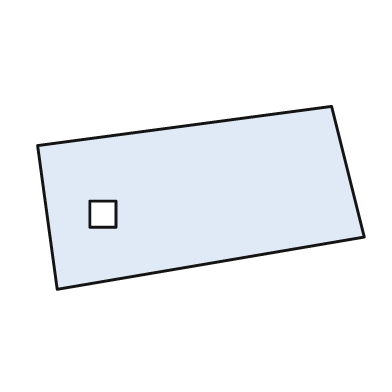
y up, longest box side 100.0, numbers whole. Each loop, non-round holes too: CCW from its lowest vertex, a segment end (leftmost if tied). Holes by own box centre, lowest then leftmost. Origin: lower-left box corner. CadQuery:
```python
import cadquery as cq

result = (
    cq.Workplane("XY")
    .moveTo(6.0, 0.0)
    .lineTo(100.0, 16.0)
    .lineTo(90.0, 56.0)
    .lineTo(0.0, 44.0)
    .close()
    .moveTo(16.0, 19.0)
    .lineTo(24.0, 19.0)
    .lineTo(24.0, 27.0)
    .lineTo(16.0, 27.0)
    .close()
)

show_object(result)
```